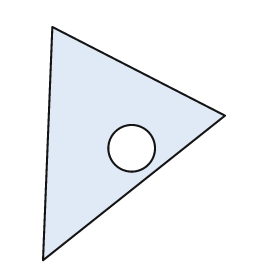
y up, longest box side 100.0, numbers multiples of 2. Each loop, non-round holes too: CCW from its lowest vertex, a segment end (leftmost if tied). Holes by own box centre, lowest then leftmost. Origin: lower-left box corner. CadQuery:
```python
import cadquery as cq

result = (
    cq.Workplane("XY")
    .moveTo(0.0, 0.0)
    .lineTo(78.0, 62.0)
    .lineTo(4.0, 100.0)
    .close()
    .moveTo(38.0, 48.0)
    .circle(10.0)
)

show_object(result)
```